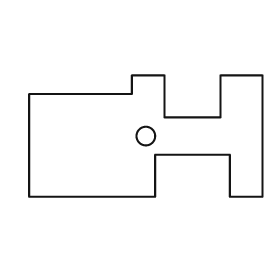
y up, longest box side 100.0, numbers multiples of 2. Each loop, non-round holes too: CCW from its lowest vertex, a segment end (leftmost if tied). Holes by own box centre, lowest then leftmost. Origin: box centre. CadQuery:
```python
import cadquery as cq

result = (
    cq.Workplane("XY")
    .moveTo(-50.0, -26.0)
    .lineTo(4.0, -26.0)
    .lineTo(4.0, -8.0)
    .lineTo(36.0, -8.0)
    .lineTo(36.0, -26.0)
    .lineTo(50.0, -26.0)
    .lineTo(50.0, 26.0)
    .lineTo(32.0, 26.0)
    .lineTo(32.0, 8.0)
    .lineTo(8.0, 8.0)
    .lineTo(8.0, 26.0)
    .lineTo(-6.0, 26.0)
    .lineTo(-6.0, 18.0)
    .lineTo(-50.0, 18.0)
    .close()
    .moveTo(0.0, 0.0)
    .circle(4.0)
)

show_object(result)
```